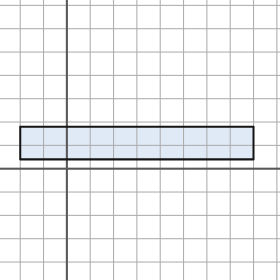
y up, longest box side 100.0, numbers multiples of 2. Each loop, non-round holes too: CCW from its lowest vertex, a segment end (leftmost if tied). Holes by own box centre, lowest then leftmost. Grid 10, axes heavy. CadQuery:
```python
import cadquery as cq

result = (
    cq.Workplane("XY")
    .moveTo(-20.0, 4.0)
    .lineTo(80.0, 4.0)
    .lineTo(80.0, 18.0)
    .lineTo(-20.0, 18.0)
    .close()
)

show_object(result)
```